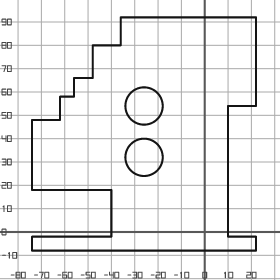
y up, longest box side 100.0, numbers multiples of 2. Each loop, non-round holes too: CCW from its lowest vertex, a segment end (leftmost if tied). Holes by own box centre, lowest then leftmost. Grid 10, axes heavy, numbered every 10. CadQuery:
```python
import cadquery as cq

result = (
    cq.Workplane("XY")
    .moveTo(-74.0, -8.0)
    .lineTo(22.0, -8.0)
    .lineTo(22.0, -2.0)
    .lineTo(10.0, -2.0)
    .lineTo(10.0, 54.0)
    .lineTo(22.0, 54.0)
    .lineTo(22.0, 92.0)
    .lineTo(-36.0, 92.0)
    .lineTo(-36.0, 80.0)
    .lineTo(-48.0, 80.0)
    .lineTo(-48.0, 66.0)
    .lineTo(-56.0, 66.0)
    .lineTo(-56.0, 58.0)
    .lineTo(-62.0, 58.0)
    .lineTo(-62.0, 48.0)
    .lineTo(-74.0, 48.0)
    .lineTo(-74.0, 18.0)
    .lineTo(-40.0, 18.0)
    .lineTo(-40.0, -2.0)
    .lineTo(-74.0, -2.0)
    .close()
    .moveTo(-26.0, 32.0)
    .circle(8.0)
    .moveTo(-26.0, 54.0)
    .circle(8.0)
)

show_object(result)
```